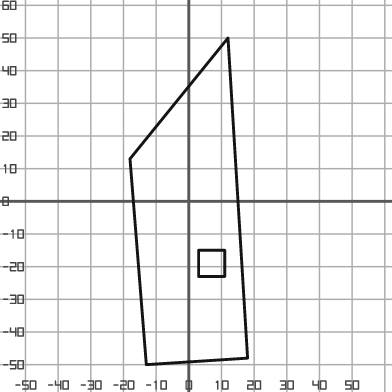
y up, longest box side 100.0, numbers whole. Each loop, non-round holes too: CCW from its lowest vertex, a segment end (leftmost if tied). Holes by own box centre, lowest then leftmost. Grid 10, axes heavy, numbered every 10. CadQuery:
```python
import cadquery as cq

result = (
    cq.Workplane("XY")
    .moveTo(-13.0, -50.0)
    .lineTo(18.0, -48.0)
    .lineTo(12.0, 50.0)
    .lineTo(-18.0, 13.0)
    .close()
    .moveTo(3.0, -23.0)
    .lineTo(11.0, -23.0)
    .lineTo(11.0, -15.0)
    .lineTo(3.0, -15.0)
    .close()
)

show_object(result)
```